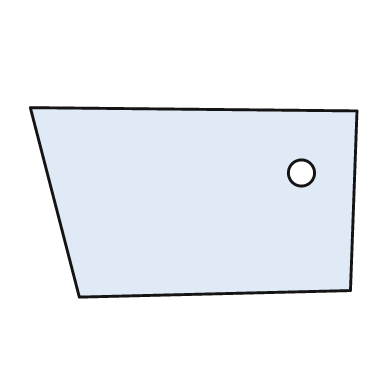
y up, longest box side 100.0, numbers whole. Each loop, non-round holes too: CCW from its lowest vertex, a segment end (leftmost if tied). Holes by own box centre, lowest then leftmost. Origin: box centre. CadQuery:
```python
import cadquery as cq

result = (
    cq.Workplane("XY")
    .moveTo(-35.0, -29.0)
    .lineTo(48.0, -27.0)
    .lineTo(50.0, 28.0)
    .lineTo(-50.0, 29.0)
    .close()
    .moveTo(33.0, 9.0)
    .circle(4.0)
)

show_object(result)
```